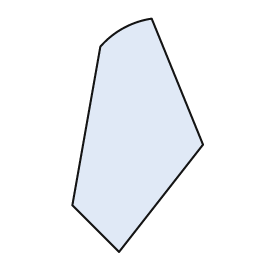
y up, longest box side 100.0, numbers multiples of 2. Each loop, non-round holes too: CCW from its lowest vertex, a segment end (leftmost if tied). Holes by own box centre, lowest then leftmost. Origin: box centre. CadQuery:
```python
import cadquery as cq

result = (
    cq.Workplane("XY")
    .moveTo(-8.0, -50.0)
    .lineTo(28.0, -4.0)
    .lineTo(6.0, 50.0)
    .threePointArc((-6.0, 46.0), (-16.0, 38.0))
    .lineTo(-28.0, -30.0)
    .close()
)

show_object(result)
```